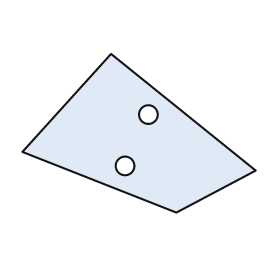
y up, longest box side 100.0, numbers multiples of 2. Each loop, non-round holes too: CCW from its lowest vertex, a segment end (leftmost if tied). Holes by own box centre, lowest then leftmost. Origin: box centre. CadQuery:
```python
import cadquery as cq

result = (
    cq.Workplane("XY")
    .moveTo(16.0, -34.0)
    .lineTo(50.0, -16.0)
    .lineTo(-12.0, 34.0)
    .lineTo(-50.0, -8.0)
    .close()
    .moveTo(-6.0, -14.0)
    .circle(4.0)
    .moveTo(4.0, 8.0)
    .circle(4.0)
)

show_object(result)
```